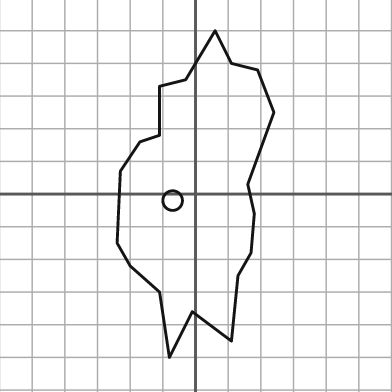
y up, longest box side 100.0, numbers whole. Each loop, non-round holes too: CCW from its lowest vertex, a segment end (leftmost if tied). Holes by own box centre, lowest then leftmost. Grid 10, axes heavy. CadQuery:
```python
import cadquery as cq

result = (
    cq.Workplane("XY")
    .moveTo(-8.0, -50.0)
    .lineTo(-1.0, -36.0)
    .lineTo(11.0, -45.0)
    .lineTo(13.0, -25.0)
    .lineTo(17.0, -18.0)
    .lineTo(18.0, -6.0)
    .lineTo(16.0, 3.0)
    .lineTo(24.0, 25.0)
    .lineTo(19.0, 38.0)
    .lineTo(11.0, 40.0)
    .lineTo(6.0, 50.0)
    .lineTo(-3.0, 35.0)
    .lineTo(-11.0, 33.0)
    .lineTo(-11.0, 18.0)
    .lineTo(-17.0, 16.0)
    .lineTo(-23.0, 7.0)
    .lineTo(-24.0, -15.0)
    .lineTo(-20.0, -22.0)
    .lineTo(-11.0, -30.0)
    .close()
    .moveTo(-7.0, -2.0)
    .circle(3.0)
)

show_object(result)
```